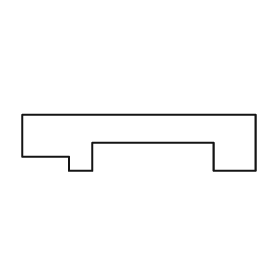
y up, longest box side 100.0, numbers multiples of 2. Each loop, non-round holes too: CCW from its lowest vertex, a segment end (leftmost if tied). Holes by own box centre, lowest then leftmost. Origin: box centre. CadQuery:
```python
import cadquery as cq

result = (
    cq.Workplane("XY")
    .moveTo(-30.0, -12.0)
    .lineTo(-20.0, -12.0)
    .lineTo(-20.0, 0.0)
    .lineTo(32.0, 0.0)
    .lineTo(32.0, -12.0)
    .lineTo(50.0, -12.0)
    .lineTo(50.0, 12.0)
    .lineTo(-50.0, 12.0)
    .lineTo(-50.0, -6.0)
    .lineTo(-30.0, -6.0)
    .close()
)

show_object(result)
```